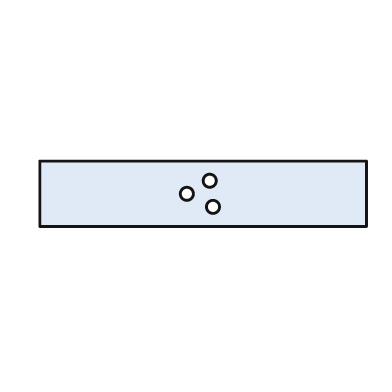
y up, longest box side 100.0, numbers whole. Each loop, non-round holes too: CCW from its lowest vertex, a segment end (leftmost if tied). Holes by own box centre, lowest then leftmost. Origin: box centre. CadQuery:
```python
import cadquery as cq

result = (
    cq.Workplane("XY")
    .moveTo(-50.0, -10.0)
    .lineTo(50.0, -10.0)
    .lineTo(50.0, 10.0)
    .lineTo(-50.0, 10.0)
    .close()
    .moveTo(3.0, -4.0)
    .circle(2.0)
    .moveTo(-5.0, 0.0)
    .circle(2.0)
    .moveTo(2.0, 4.0)
    .circle(2.0)
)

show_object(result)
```